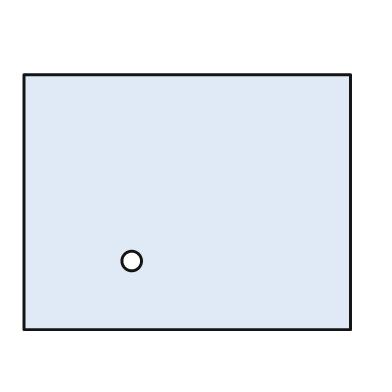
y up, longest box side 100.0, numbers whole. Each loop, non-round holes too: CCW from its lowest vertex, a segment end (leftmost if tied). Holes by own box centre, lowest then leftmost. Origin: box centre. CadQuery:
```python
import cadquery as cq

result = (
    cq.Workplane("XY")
    .moveTo(-50.0, -39.0)
    .lineTo(50.0, -39.0)
    .lineTo(50.0, 39.0)
    .lineTo(-50.0, 39.0)
    .close()
    .moveTo(-17.0, -18.0)
    .circle(3.0)
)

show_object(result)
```